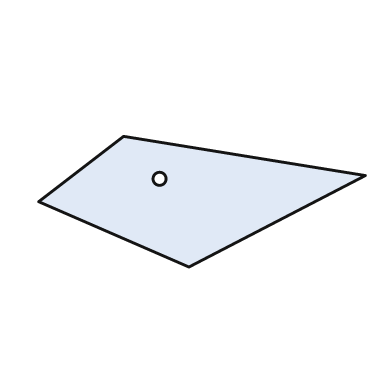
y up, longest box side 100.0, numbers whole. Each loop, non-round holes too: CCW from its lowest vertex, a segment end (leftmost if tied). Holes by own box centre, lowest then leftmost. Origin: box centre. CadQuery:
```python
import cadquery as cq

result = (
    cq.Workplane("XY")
    .moveTo(-4.0, -20.0)
    .lineTo(50.0, 8.0)
    .lineTo(-24.0, 20.0)
    .lineTo(-50.0, 0.0)
    .close()
    .moveTo(-13.0, 7.0)
    .circle(2.0)
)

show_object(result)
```